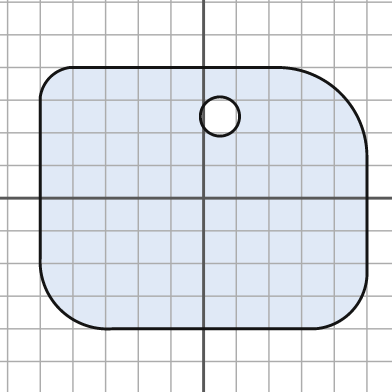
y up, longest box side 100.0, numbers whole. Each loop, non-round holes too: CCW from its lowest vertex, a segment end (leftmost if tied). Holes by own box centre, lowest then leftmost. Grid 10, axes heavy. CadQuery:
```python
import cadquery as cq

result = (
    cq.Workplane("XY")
    .moveTo(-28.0, -40.0)
    .lineTo(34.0, -40.0)
    .threePointArc((45.0, -35.0), (50.0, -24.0))
    .lineTo(50.0, 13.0)
    .threePointArc((42.0, 32.0), (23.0, 40.0))
    .lineTo(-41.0, 40.0)
    .threePointArc((-47.0, 37.0), (-50.0, 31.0))
    .lineTo(-50.0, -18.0)
    .threePointArc((-44.0, -34.0), (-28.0, -40.0))
    .close()
    .moveTo(5.0, 25.0)
    .circle(6.0)
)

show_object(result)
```